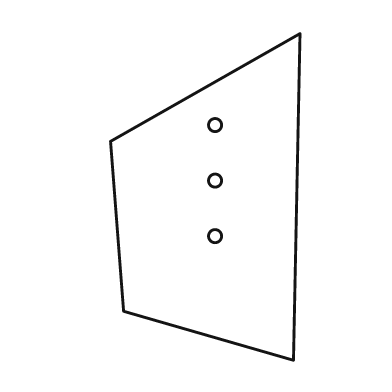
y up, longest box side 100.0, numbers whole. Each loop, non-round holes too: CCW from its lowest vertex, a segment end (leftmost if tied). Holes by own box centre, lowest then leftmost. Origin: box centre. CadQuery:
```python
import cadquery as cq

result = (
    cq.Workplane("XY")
    .moveTo(27.0, -50.0)
    .lineTo(29.0, 50.0)
    .lineTo(-29.0, 17.0)
    .lineTo(-25.0, -35.0)
    .close()
    .moveTo(3.0, -12.0)
    .circle(2.0)
    .moveTo(3.0, 5.0)
    .circle(2.0)
    .moveTo(3.0, 22.0)
    .circle(2.0)
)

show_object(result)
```